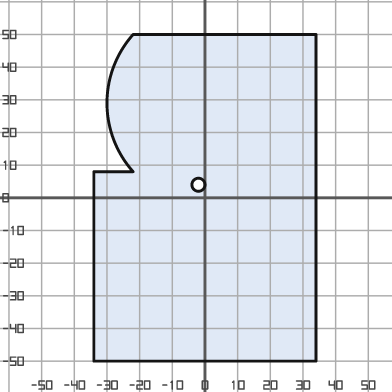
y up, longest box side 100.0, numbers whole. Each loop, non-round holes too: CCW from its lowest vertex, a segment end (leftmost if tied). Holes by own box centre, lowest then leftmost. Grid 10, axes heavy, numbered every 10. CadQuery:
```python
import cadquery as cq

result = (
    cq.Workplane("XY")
    .moveTo(-34.0, -50.0)
    .lineTo(34.0, -50.0)
    .lineTo(34.0, 50.0)
    .lineTo(-22.0, 50.0)
    .threePointArc((-30.0, 29.0), (-22.0, 8.0))
    .lineTo(-34.0, 8.0)
    .close()
    .moveTo(-2.0, 4.0)
    .circle(2.0)
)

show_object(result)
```